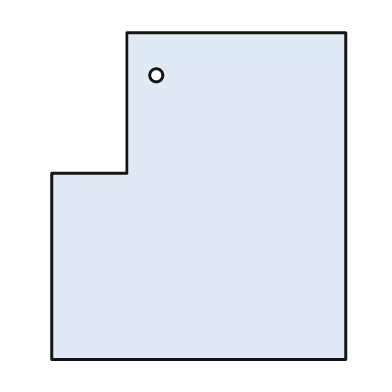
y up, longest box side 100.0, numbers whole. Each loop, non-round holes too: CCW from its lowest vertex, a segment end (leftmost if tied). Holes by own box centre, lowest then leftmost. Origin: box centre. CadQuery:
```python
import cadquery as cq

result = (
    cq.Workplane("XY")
    .moveTo(-45.0, -50.0)
    .lineTo(45.0, -50.0)
    .lineTo(45.0, 50.0)
    .lineTo(-22.0, 50.0)
    .lineTo(-22.0, 7.0)
    .lineTo(-45.0, 7.0)
    .close()
    .moveTo(-13.0, 37.0)
    .circle(2.0)
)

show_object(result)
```